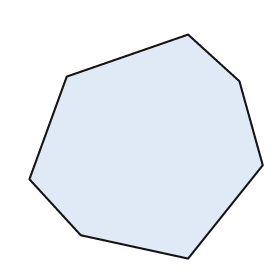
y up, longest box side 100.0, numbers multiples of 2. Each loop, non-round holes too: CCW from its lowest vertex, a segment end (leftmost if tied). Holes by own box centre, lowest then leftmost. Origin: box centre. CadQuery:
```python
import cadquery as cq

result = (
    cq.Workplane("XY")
    .moveTo(18.0, -48.0)
    .lineTo(50.0, -8.0)
    .lineTo(40.0, 28.0)
    .lineTo(18.0, 48.0)
    .lineTo(-34.0, 30.0)
    .lineTo(-50.0, -14.0)
    .lineTo(-28.0, -38.0)
    .close()
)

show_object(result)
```